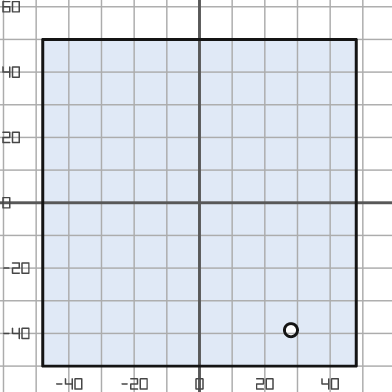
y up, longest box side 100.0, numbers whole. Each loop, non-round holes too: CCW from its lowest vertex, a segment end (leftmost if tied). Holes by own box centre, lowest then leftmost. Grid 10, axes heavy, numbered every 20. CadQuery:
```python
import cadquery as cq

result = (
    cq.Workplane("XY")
    .moveTo(-48.0, -50.0)
    .lineTo(48.0, -50.0)
    .lineTo(48.0, 50.0)
    .lineTo(-48.0, 50.0)
    .close()
    .moveTo(28.0, -39.0)
    .circle(2.0)
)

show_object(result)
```